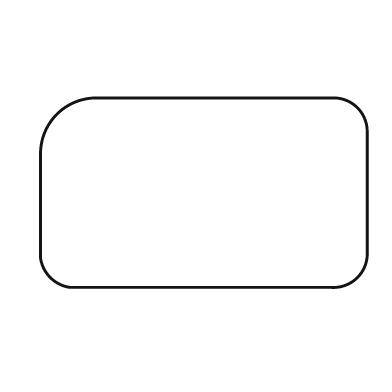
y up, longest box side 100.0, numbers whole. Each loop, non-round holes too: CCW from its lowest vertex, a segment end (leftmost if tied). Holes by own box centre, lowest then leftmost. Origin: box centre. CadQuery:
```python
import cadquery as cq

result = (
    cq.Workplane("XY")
    .moveTo(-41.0, -29.0)
    .lineTo(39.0, -29.0)
    .threePointArc((47.0, -26.0), (50.0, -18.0))
    .lineTo(50.0, 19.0)
    .threePointArc((47.0, 26.0), (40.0, 29.0))
    .lineTo(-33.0, 29.0)
    .threePointArc((-45.0, 24.0), (-50.0, 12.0))
    .lineTo(-50.0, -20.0)
    .threePointArc((-47.0, -26.0), (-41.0, -29.0))
    .close()
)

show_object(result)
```